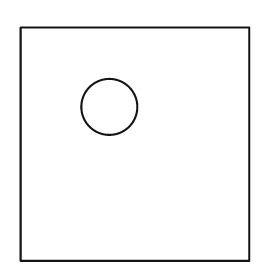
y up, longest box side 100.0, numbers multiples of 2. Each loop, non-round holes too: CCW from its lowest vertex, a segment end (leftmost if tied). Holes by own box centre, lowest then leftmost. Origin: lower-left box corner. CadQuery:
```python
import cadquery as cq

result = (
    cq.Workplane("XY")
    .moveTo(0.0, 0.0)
    .lineTo(98.0, 0.0)
    .lineTo(98.0, 100.0)
    .lineTo(0.0, 100.0)
    .close()
    .moveTo(38.0, 66.0)
    .circle(12.0)
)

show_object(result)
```